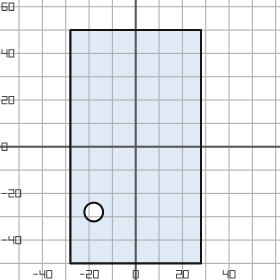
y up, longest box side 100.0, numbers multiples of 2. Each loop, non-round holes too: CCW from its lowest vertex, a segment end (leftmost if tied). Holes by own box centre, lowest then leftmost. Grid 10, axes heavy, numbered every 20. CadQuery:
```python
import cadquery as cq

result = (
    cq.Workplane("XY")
    .moveTo(-28.0, -50.0)
    .lineTo(28.0, -50.0)
    .lineTo(28.0, 50.0)
    .lineTo(-28.0, 50.0)
    .close()
    .moveTo(-18.0, -28.0)
    .circle(4.0)
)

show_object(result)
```